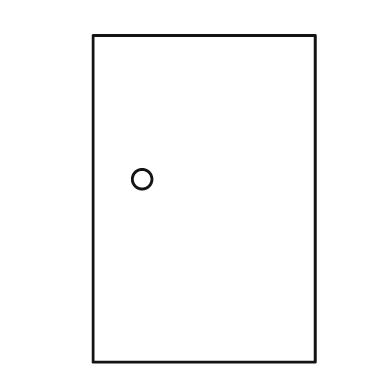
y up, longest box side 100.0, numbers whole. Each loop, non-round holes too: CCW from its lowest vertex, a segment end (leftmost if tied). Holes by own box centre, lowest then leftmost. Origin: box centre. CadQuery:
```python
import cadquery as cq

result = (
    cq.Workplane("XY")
    .moveTo(-34.0, -50.0)
    .lineTo(34.0, -50.0)
    .lineTo(34.0, 50.0)
    .lineTo(-34.0, 50.0)
    .close()
    .moveTo(-19.0, 6.0)
    .circle(3.0)
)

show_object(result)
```